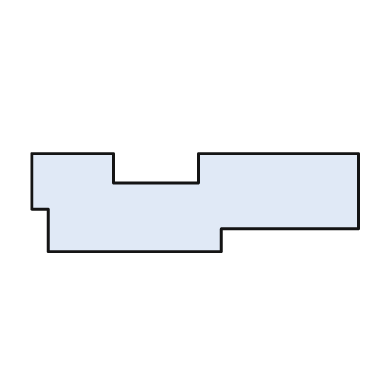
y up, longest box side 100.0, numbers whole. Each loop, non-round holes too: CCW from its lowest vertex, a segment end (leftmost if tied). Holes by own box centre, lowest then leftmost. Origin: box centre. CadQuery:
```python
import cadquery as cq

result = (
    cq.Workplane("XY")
    .moveTo(-45.0, -15.0)
    .lineTo(8.0, -15.0)
    .lineTo(8.0, -8.0)
    .lineTo(50.0, -8.0)
    .lineTo(50.0, 15.0)
    .lineTo(1.0, 15.0)
    .lineTo(1.0, 6.0)
    .lineTo(-25.0, 6.0)
    .lineTo(-25.0, 15.0)
    .lineTo(-50.0, 15.0)
    .lineTo(-50.0, -2.0)
    .lineTo(-45.0, -2.0)
    .close()
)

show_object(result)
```